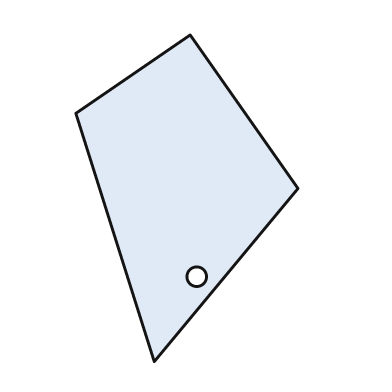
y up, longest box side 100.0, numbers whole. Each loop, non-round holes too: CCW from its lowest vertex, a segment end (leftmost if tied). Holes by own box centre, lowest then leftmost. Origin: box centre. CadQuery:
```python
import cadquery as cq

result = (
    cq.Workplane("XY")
    .moveTo(-10.0, -50.0)
    .lineTo(34.0, 3.0)
    .lineTo(1.0, 50.0)
    .lineTo(-34.0, 26.0)
    .close()
    .moveTo(3.0, -24.0)
    .circle(3.0)
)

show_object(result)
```